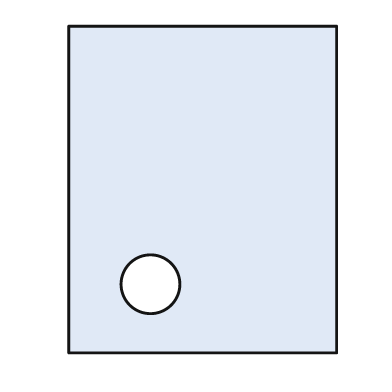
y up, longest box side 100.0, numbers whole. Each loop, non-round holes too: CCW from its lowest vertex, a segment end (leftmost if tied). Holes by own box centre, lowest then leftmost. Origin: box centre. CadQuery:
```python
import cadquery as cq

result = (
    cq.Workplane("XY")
    .moveTo(-41.0, -50.0)
    .lineTo(41.0, -50.0)
    .lineTo(41.0, 50.0)
    .lineTo(-41.0, 50.0)
    .close()
    .moveTo(-16.0, -29.0)
    .circle(9.0)
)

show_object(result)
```